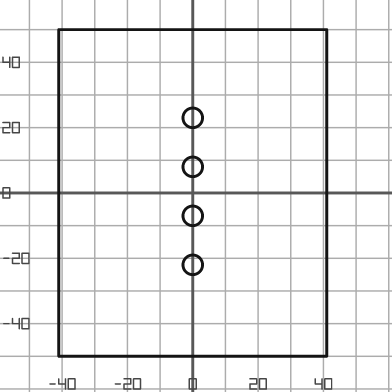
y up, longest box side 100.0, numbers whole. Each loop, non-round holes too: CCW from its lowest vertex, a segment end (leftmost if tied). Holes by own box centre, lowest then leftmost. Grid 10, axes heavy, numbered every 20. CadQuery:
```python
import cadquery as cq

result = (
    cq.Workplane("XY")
    .moveTo(-41.0, -50.0)
    .lineTo(41.0, -50.0)
    .lineTo(41.0, 50.0)
    .lineTo(-41.0, 50.0)
    .close()
    .moveTo(0.0, -22.0)
    .circle(3.0)
    .moveTo(0.0, -7.0)
    .circle(3.0)
    .moveTo(0.0, 8.0)
    .circle(3.0)
    .moveTo(0.0, 23.0)
    .circle(3.0)
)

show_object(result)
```